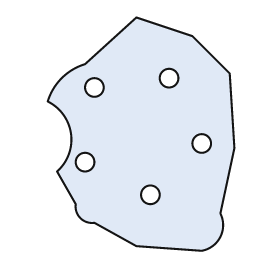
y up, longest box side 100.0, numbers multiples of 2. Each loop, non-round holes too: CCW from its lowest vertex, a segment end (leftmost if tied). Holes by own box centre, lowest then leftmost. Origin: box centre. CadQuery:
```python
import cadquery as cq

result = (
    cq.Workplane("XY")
    .moveTo(26.0, -50.0)
    .threePointArc((34.0, -44.0), (34.0, -34.0))
    .lineTo(40.0, -6.0)
    .lineTo(38.0, 26.0)
    .lineTo(22.0, 42.0)
    .lineTo(-2.0, 50.0)
    .lineTo(-24.0, 30.0)
    .threePointArc((-34.0, 24.0), (-40.0, 14.0))
    .threePointArc((-30.0, 0.0), (-36.0, -16.0))
    .lineTo(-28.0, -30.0)
    .threePointArc((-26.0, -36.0), (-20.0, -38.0))
    .lineTo(-2.0, -48.0)
    .close()
    .moveTo(4.0, -26.0)
    .circle(4.0)
    .moveTo(-24.0, -12.0)
    .circle(4.0)
    .moveTo(26.0, -4.0)
    .circle(4.0)
    .moveTo(-20.0, 20.0)
    .circle(4.0)
    .moveTo(12.0, 24.0)
    .circle(4.0)
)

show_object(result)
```